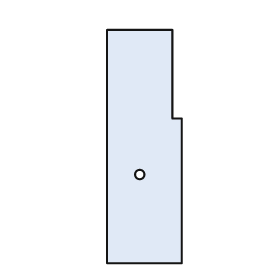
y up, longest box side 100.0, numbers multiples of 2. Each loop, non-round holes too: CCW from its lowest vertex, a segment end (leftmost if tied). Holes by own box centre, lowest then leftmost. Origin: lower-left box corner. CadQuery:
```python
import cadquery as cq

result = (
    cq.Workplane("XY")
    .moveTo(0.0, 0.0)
    .lineTo(32.0, 0.0)
    .lineTo(32.0, 62.0)
    .lineTo(28.0, 62.0)
    .lineTo(28.0, 100.0)
    .lineTo(0.0, 100.0)
    .close()
    .moveTo(14.0, 38.0)
    .circle(2.0)
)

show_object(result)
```